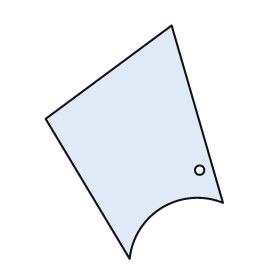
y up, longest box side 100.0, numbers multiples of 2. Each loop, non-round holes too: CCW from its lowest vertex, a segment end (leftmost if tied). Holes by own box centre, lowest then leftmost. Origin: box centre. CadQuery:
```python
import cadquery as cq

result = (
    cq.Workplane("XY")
    .moveTo(-2.0, -50.0)
    .threePointArc((12.0, -28.0), (38.0, -26.0))
    .lineTo(16.0, 50.0)
    .lineTo(-38.0, 10.0)
    .close()
    .moveTo(28.0, -12.0)
    .circle(2.0)
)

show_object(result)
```